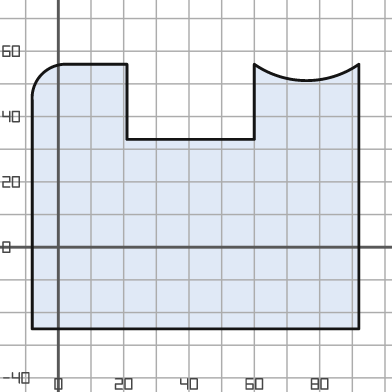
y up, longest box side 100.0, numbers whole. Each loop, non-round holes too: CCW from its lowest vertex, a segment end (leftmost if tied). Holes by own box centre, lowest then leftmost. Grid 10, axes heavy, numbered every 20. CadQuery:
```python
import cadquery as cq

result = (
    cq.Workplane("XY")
    .moveTo(-8.0, -25.0)
    .lineTo(92.0, -25.0)
    .lineTo(92.0, 56.0)
    .threePointArc((76.0, 51.0), (60.0, 56.0))
    .lineTo(60.0, 33.0)
    .lineTo(21.0, 33.0)
    .lineTo(21.0, 56.0)
    .lineTo(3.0, 56.0)
    .threePointArc((-5.0, 53.0), (-8.0, 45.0))
    .close()
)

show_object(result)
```